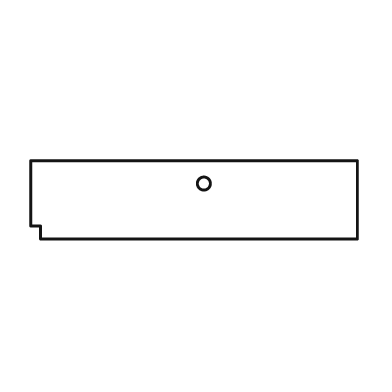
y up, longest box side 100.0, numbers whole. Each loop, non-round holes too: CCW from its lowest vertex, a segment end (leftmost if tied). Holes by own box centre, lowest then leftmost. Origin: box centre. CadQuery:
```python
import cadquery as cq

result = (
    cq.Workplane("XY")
    .moveTo(-47.0, -12.0)
    .lineTo(50.0, -12.0)
    .lineTo(50.0, 12.0)
    .lineTo(-50.0, 12.0)
    .lineTo(-50.0, -8.0)
    .lineTo(-47.0, -8.0)
    .close()
    .moveTo(3.0, 5.0)
    .circle(2.0)
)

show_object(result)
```